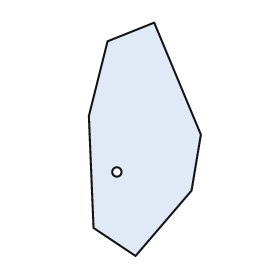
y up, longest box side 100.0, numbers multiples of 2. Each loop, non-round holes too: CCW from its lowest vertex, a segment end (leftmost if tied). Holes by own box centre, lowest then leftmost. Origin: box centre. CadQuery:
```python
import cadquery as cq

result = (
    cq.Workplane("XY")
    .moveTo(-4.0, -50.0)
    .lineTo(20.0, -22.0)
    .lineTo(24.0, 2.0)
    .lineTo(4.0, 50.0)
    .lineTo(-16.0, 42.0)
    .lineTo(-24.0, 10.0)
    .lineTo(-22.0, -38.0)
    .close()
    .moveTo(-12.0, -14.0)
    .circle(2.0)
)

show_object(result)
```